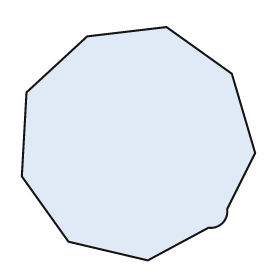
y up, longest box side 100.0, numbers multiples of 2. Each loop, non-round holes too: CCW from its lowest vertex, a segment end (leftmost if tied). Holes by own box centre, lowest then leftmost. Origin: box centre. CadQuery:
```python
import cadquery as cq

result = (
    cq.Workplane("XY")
    .moveTo(4.0, -50.0)
    .lineTo(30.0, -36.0)
    .threePointArc((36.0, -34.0), (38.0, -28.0))
    .lineTo(50.0, -4.0)
    .lineTo(40.0, 30.0)
    .lineTo(12.0, 50.0)
    .lineTo(-22.0, 46.0)
    .lineTo(-48.0, 22.0)
    .lineTo(-50.0, -14.0)
    .lineTo(-30.0, -42.0)
    .close()
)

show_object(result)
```